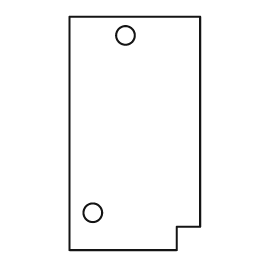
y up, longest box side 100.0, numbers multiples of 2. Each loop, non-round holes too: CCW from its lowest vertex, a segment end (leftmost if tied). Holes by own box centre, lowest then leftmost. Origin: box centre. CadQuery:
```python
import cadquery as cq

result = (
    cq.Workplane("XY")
    .moveTo(-28.0, -50.0)
    .lineTo(18.0, -50.0)
    .lineTo(18.0, -40.0)
    .lineTo(28.0, -40.0)
    .lineTo(28.0, 50.0)
    .lineTo(-28.0, 50.0)
    .close()
    .moveTo(-18.0, -34.0)
    .circle(4.0)
    .moveTo(-4.0, 42.0)
    .circle(4.0)
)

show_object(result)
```